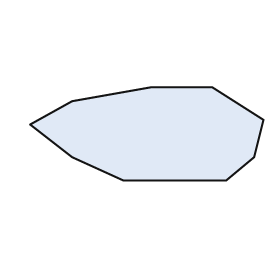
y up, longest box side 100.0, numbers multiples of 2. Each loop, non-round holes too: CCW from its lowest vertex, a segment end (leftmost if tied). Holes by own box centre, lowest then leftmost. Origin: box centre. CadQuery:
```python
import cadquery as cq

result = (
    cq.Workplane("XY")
    .moveTo(-10.0, -20.0)
    .lineTo(34.0, -20.0)
    .lineTo(46.0, -10.0)
    .lineTo(50.0, 6.0)
    .lineTo(28.0, 20.0)
    .lineTo(2.0, 20.0)
    .lineTo(-32.0, 14.0)
    .lineTo(-50.0, 4.0)
    .lineTo(-32.0, -10.0)
    .close()
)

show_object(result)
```